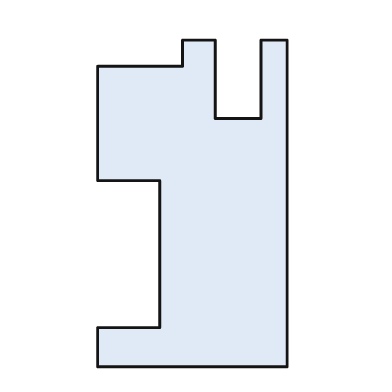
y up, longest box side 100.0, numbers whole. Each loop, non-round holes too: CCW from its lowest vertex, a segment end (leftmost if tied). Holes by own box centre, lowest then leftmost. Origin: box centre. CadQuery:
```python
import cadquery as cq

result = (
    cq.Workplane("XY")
    .moveTo(-29.0, -50.0)
    .lineTo(29.0, -50.0)
    .lineTo(29.0, 50.0)
    .lineTo(21.0, 50.0)
    .lineTo(21.0, 26.0)
    .lineTo(7.0, 26.0)
    .lineTo(7.0, 50.0)
    .lineTo(-3.0, 50.0)
    .lineTo(-3.0, 42.0)
    .lineTo(-29.0, 42.0)
    .lineTo(-29.0, 7.0)
    .lineTo(-10.0, 7.0)
    .lineTo(-10.0, -38.0)
    .lineTo(-29.0, -38.0)
    .close()
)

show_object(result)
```